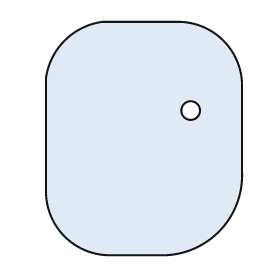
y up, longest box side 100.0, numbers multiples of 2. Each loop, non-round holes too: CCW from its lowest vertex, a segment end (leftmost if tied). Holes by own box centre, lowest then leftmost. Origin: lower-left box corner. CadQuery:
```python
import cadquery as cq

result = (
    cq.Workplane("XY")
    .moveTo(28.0, 0.0)
    .lineTo(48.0, 0.0)
    .threePointArc((74.0, 10.0), (84.0, 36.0))
    .lineTo(84.0, 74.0)
    .threePointArc((76.0, 92.0), (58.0, 100.0))
    .lineTo(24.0, 100.0)
    .threePointArc((8.0, 92.0), (0.0, 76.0))
    .lineTo(0.0, 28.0)
    .threePointArc((8.0, 8.0), (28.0, 0.0))
    .close()
    .moveTo(62.0, 62.0)
    .circle(4.0)
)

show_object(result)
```